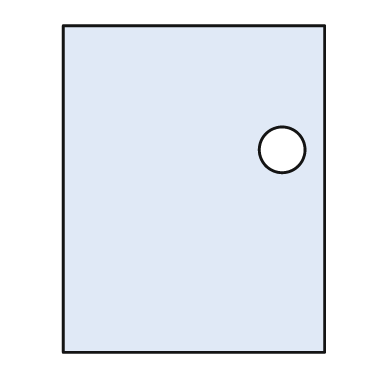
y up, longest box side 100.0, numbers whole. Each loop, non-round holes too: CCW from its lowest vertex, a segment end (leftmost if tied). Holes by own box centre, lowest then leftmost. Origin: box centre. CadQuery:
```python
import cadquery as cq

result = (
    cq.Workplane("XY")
    .moveTo(-40.0, -50.0)
    .lineTo(40.0, -50.0)
    .lineTo(40.0, 50.0)
    .lineTo(-40.0, 50.0)
    .close()
    .moveTo(27.0, 12.0)
    .circle(7.0)
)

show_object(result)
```